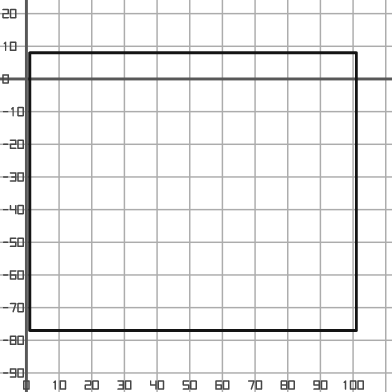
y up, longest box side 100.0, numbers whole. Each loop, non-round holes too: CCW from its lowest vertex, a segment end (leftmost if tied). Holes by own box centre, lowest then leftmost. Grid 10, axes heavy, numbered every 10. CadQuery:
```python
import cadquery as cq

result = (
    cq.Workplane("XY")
    .moveTo(1.0, -77.0)
    .lineTo(101.0, -77.0)
    .lineTo(101.0, 8.0)
    .lineTo(1.0, 8.0)
    .close()
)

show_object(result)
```